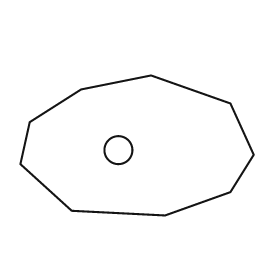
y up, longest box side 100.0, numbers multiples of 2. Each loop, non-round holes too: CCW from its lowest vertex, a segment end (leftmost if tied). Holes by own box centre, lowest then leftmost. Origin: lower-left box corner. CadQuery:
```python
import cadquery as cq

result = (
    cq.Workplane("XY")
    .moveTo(62.0, 0.0)
    .lineTo(90.0, 10.0)
    .lineTo(100.0, 26.0)
    .lineTo(90.0, 48.0)
    .lineTo(56.0, 60.0)
    .lineTo(26.0, 54.0)
    .lineTo(4.0, 40.0)
    .lineTo(0.0, 22.0)
    .lineTo(22.0, 2.0)
    .close()
    .moveTo(42.0, 28.0)
    .circle(6.0)
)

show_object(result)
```